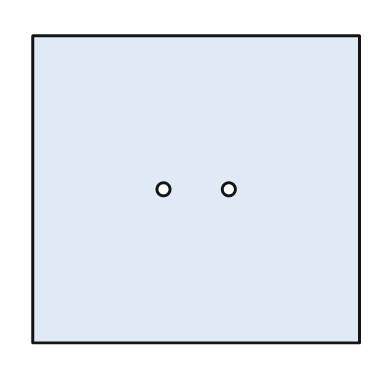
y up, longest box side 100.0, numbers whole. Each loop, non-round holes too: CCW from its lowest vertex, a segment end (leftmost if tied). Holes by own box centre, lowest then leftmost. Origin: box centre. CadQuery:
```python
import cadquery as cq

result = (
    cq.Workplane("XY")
    .moveTo(-50.0, -47.0)
    .lineTo(50.0, -47.0)
    .lineTo(50.0, 47.0)
    .lineTo(-50.0, 47.0)
    .close()
    .moveTo(-10.0, 0.0)
    .circle(2.0)
    .moveTo(10.0, 0.0)
    .circle(2.0)
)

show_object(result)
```